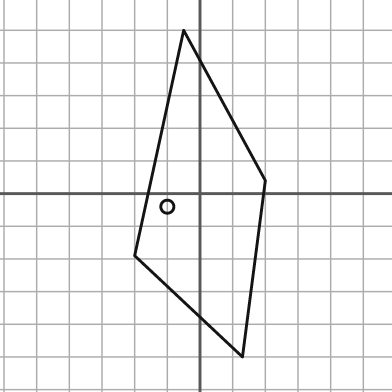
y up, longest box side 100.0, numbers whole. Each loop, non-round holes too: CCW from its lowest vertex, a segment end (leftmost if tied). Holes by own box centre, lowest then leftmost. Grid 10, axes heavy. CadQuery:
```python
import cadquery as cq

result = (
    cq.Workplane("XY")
    .moveTo(13.0, -50.0)
    .lineTo(20.0, 4.0)
    .lineTo(-5.0, 50.0)
    .lineTo(-20.0, -19.0)
    .close()
    .moveTo(-10.0, -4.0)
    .circle(2.0)
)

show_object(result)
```